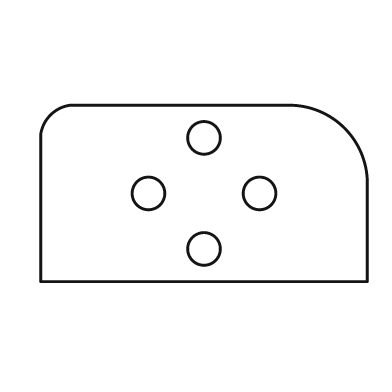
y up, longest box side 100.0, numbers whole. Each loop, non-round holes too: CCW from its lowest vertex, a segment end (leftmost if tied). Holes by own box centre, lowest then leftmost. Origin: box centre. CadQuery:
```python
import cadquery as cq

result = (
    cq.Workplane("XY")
    .moveTo(-50.0, -27.0)
    .lineTo(50.0, -27.0)
    .lineTo(50.0, 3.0)
    .threePointArc((43.0, 20.0), (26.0, 27.0))
    .lineTo(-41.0, 27.0)
    .threePointArc((-47.0, 24.0), (-50.0, 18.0))
    .close()
    .moveTo(0.0, -17.0)
    .circle(5.0)
    .moveTo(-17.0, 0.0)
    .circle(5.0)
    .moveTo(17.0, 0.0)
    .circle(5.0)
    .moveTo(0.0, 17.0)
    .circle(5.0)
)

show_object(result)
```